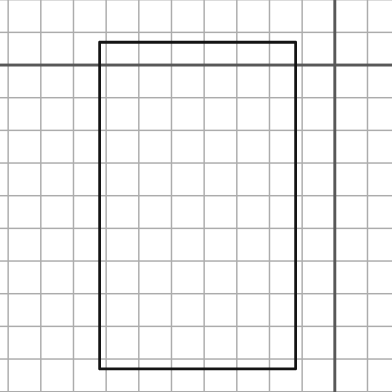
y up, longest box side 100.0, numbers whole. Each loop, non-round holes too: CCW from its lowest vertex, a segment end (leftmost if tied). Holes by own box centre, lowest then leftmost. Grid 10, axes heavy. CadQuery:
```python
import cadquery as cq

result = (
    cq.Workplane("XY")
    .moveTo(-72.0, -93.0)
    .lineTo(-12.0, -93.0)
    .lineTo(-12.0, 7.0)
    .lineTo(-72.0, 7.0)
    .close()
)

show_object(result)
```